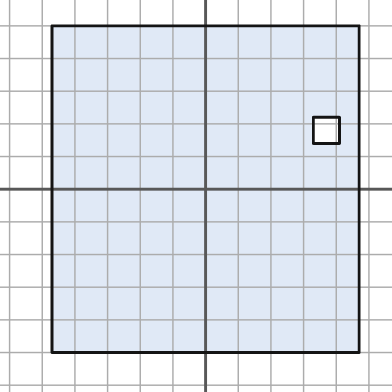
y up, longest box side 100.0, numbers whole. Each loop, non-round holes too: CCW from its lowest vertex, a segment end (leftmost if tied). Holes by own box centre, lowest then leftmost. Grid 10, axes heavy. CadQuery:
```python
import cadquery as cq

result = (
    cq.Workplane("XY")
    .moveTo(-47.0, -50.0)
    .lineTo(47.0, -50.0)
    .lineTo(47.0, 50.0)
    .lineTo(-47.0, 50.0)
    .close()
    .moveTo(33.0, 14.0)
    .lineTo(41.0, 14.0)
    .lineTo(41.0, 22.0)
    .lineTo(33.0, 22.0)
    .close()
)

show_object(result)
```